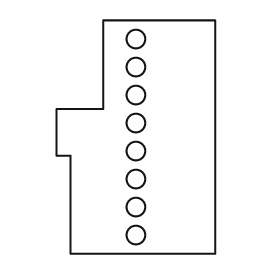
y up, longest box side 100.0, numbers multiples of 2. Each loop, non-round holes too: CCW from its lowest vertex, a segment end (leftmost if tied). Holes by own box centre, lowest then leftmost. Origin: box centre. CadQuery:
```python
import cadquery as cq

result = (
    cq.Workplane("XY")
    .moveTo(-28.0, -50.0)
    .lineTo(34.0, -50.0)
    .lineTo(34.0, 50.0)
    .lineTo(-14.0, 50.0)
    .lineTo(-14.0, 12.0)
    .lineTo(-34.0, 12.0)
    .lineTo(-34.0, -8.0)
    .lineTo(-28.0, -8.0)
    .close()
    .moveTo(0.0, -42.0)
    .circle(4.0)
    .moveTo(0.0, -30.0)
    .circle(4.0)
    .moveTo(0.0, -18.0)
    .circle(4.0)
    .moveTo(0.0, -6.0)
    .circle(4.0)
    .moveTo(0.0, 6.0)
    .circle(4.0)
    .moveTo(0.0, 18.0)
    .circle(4.0)
    .moveTo(0.0, 30.0)
    .circle(4.0)
    .moveTo(0.0, 42.0)
    .circle(4.0)
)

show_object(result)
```